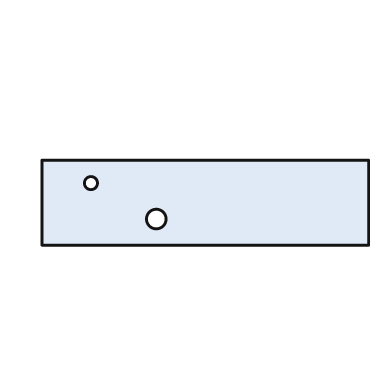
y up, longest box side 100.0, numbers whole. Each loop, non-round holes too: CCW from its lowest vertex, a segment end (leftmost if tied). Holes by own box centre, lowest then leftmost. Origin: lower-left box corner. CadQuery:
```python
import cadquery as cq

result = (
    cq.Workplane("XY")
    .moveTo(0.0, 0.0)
    .lineTo(100.0, 0.0)
    .lineTo(100.0, 26.0)
    .lineTo(0.0, 26.0)
    .close()
    .moveTo(35.0, 8.0)
    .circle(3.0)
    .moveTo(15.0, 19.0)
    .circle(2.0)
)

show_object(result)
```